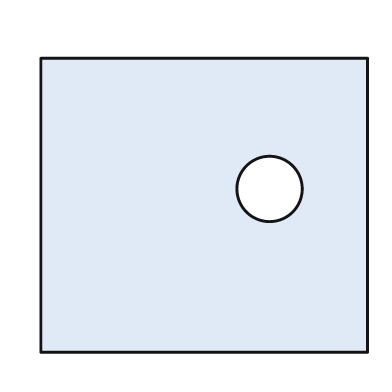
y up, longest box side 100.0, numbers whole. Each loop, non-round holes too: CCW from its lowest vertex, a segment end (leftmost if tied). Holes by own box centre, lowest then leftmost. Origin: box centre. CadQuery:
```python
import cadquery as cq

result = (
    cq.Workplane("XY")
    .moveTo(-50.0, -45.0)
    .lineTo(50.0, -45.0)
    .lineTo(50.0, 45.0)
    .lineTo(-50.0, 45.0)
    .close()
    .moveTo(20.0, 5.0)
    .circle(10.0)
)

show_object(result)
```